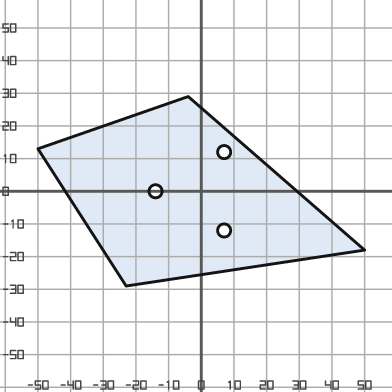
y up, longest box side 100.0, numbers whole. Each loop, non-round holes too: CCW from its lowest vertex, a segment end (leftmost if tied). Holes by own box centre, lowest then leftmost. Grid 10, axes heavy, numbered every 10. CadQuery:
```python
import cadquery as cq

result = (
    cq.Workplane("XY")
    .moveTo(-23.0, -29.0)
    .lineTo(50.0, -18.0)
    .lineTo(-4.0, 29.0)
    .lineTo(-50.0, 13.0)
    .close()
    .moveTo(7.0, -12.0)
    .circle(2.0)
    .moveTo(-14.0, 0.0)
    .circle(2.0)
    .moveTo(7.0, 12.0)
    .circle(2.0)
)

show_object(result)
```